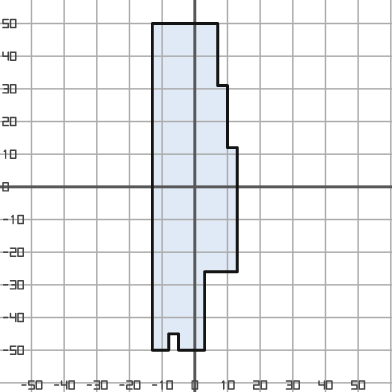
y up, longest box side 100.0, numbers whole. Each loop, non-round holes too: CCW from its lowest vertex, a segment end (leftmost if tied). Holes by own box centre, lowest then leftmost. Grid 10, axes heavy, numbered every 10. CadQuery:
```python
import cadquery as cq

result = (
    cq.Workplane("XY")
    .moveTo(-13.0, -50.0)
    .lineTo(-8.0, -50.0)
    .lineTo(-8.0, -45.0)
    .lineTo(-5.0, -45.0)
    .lineTo(-5.0, -50.0)
    .lineTo(3.0, -50.0)
    .lineTo(3.0, -26.0)
    .lineTo(13.0, -26.0)
    .lineTo(13.0, 12.0)
    .lineTo(10.0, 12.0)
    .lineTo(10.0, 31.0)
    .lineTo(7.0, 31.0)
    .lineTo(7.0, 50.0)
    .lineTo(-13.0, 50.0)
    .close()
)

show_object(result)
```